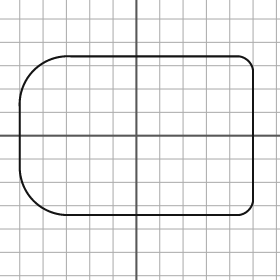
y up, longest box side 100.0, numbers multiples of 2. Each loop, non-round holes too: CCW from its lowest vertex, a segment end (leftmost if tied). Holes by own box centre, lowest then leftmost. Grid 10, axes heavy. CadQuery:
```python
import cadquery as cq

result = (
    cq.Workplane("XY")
    .moveTo(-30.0, -34.0)
    .lineTo(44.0, -34.0)
    .threePointArc((48.0, -32.0), (50.0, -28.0))
    .lineTo(50.0, 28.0)
    .threePointArc((48.0, 32.0), (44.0, 34.0))
    .lineTo(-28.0, 34.0)
    .threePointArc((-44.0, 28.0), (-50.0, 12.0))
    .lineTo(-50.0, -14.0)
    .threePointArc((-44.0, -28.0), (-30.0, -34.0))
    .close()
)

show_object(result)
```